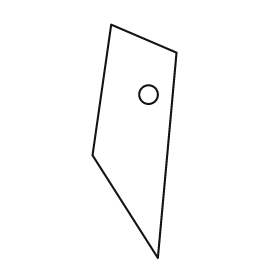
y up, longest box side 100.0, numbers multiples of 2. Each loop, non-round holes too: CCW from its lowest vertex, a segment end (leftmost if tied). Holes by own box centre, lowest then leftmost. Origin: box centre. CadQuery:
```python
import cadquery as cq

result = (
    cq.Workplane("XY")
    .moveTo(10.0, -50.0)
    .lineTo(18.0, 38.0)
    .lineTo(-10.0, 50.0)
    .lineTo(-18.0, -6.0)
    .close()
    .moveTo(6.0, 20.0)
    .circle(4.0)
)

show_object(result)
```